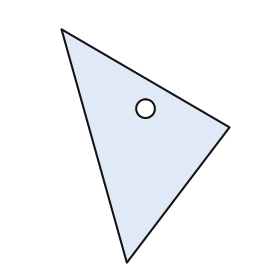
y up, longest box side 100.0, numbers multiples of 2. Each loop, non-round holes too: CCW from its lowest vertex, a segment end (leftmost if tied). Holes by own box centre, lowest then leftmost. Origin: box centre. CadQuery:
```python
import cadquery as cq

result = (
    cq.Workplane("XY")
    .moveTo(-8.0, -50.0)
    .lineTo(36.0, 8.0)
    .lineTo(-36.0, 50.0)
    .close()
    .moveTo(0.0, 16.0)
    .circle(4.0)
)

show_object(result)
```